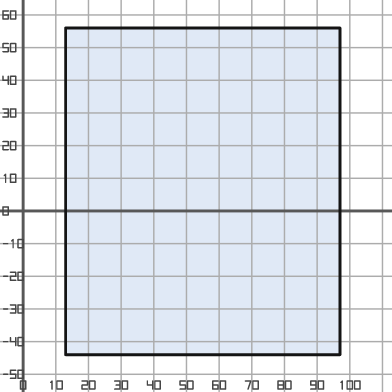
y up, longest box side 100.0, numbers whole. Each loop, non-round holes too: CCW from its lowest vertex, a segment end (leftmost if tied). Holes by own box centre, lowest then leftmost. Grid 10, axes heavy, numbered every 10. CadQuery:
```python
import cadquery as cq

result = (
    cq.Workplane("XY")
    .moveTo(13.0, -44.0)
    .lineTo(97.0, -44.0)
    .lineTo(97.0, 56.0)
    .lineTo(13.0, 56.0)
    .close()
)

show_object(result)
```